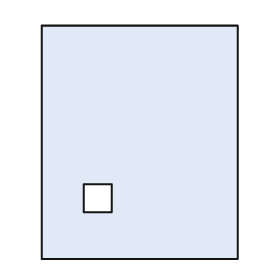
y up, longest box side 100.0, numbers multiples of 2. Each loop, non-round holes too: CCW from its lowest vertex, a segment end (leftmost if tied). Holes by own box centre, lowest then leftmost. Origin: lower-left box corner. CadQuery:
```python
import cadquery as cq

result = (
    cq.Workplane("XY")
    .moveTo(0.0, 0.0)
    .lineTo(84.0, 0.0)
    .lineTo(84.0, 100.0)
    .lineTo(0.0, 100.0)
    .close()
    .moveTo(18.0, 20.0)
    .lineTo(30.0, 20.0)
    .lineTo(30.0, 32.0)
    .lineTo(18.0, 32.0)
    .close()
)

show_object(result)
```